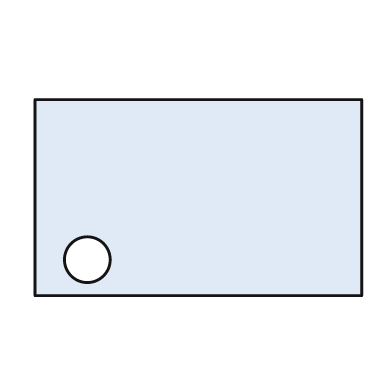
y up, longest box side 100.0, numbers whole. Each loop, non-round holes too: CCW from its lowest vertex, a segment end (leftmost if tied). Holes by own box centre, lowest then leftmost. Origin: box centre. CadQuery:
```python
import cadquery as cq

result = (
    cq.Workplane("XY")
    .moveTo(-50.0, -30.0)
    .lineTo(50.0, -30.0)
    .lineTo(50.0, 30.0)
    .lineTo(-50.0, 30.0)
    .close()
    .moveTo(-34.0, -19.0)
    .circle(7.0)
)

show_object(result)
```